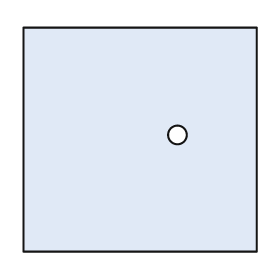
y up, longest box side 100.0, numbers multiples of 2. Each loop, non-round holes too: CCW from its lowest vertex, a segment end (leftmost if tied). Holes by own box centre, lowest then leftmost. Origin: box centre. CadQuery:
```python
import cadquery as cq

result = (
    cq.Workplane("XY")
    .moveTo(-50.0, -48.0)
    .lineTo(50.0, -48.0)
    .lineTo(50.0, 48.0)
    .lineTo(-50.0, 48.0)
    .close()
    .moveTo(16.0, 2.0)
    .circle(4.0)
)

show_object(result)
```